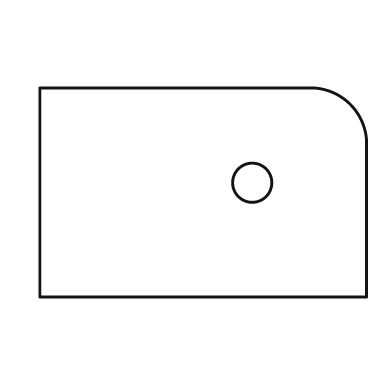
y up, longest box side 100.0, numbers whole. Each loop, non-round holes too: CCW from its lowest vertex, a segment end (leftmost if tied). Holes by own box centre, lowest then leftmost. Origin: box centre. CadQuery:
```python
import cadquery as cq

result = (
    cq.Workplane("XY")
    .moveTo(-50.0, -32.0)
    .lineTo(50.0, -32.0)
    .lineTo(50.0, 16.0)
    .threePointArc((45.0, 27.0), (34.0, 32.0))
    .lineTo(-50.0, 32.0)
    .close()
    .moveTo(15.0, 3.0)
    .circle(6.0)
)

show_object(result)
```